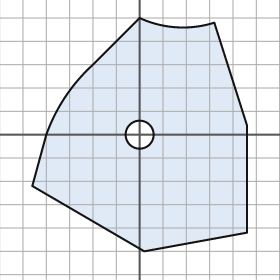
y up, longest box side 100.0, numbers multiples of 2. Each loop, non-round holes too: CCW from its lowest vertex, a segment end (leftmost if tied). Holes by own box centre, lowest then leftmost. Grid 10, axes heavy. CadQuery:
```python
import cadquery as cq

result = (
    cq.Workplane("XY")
    .moveTo(2.0, -50.0)
    .lineTo(46.0, -42.0)
    .lineTo(46.0, 4.0)
    .lineTo(32.0, 48.0)
    .threePointArc((16.0, 46.0), (0.0, 50.0))
    .lineTo(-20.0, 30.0)
    .threePointArc((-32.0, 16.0), (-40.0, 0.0))
    .lineTo(-46.0, -22.0)
    .close()
    .moveTo(0.0, 0.0)
    .circle(6.0)
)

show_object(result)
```